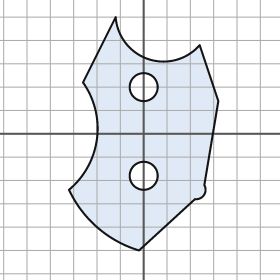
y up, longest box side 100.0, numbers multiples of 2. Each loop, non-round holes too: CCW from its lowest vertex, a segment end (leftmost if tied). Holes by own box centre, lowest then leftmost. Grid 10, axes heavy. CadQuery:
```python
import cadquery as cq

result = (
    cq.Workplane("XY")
    .moveTo(-2.0, -50.0)
    .lineTo(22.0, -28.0)
    .threePointArc((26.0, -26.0), (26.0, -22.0))
    .lineTo(32.0, 14.0)
    .lineTo(24.0, 38.0)
    .threePointArc((2.0, 32.0), (-12.0, 50.0))
    .lineTo(-26.0, 22.0)
    .threePointArc((-20.0, -2.0), (-32.0, -24.0))
    .threePointArc((-20.0, -40.0), (-2.0, -50.0))
    .close()
    .moveTo(0.0, -18.0)
    .circle(6.0)
    .moveTo(0.0, 20.0)
    .circle(6.0)
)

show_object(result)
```